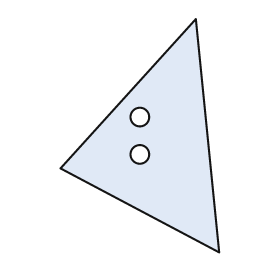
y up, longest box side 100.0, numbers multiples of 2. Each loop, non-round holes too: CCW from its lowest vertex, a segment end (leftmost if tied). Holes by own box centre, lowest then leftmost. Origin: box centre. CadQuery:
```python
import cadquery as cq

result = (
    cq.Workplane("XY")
    .moveTo(34.0, -50.0)
    .lineTo(24.0, 50.0)
    .lineTo(-34.0, -14.0)
    .close()
    .moveTo(0.0, -8.0)
    .circle(4.0)
    .moveTo(0.0, 8.0)
    .circle(4.0)
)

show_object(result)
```